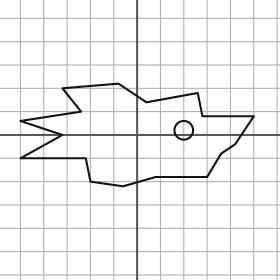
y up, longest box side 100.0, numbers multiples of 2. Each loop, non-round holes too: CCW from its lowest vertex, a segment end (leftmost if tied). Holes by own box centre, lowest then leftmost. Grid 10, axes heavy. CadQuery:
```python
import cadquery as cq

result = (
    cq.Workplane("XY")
    .moveTo(-6.0, -22.0)
    .lineTo(8.0, -18.0)
    .lineTo(30.0, -18.0)
    .lineTo(36.0, -8.0)
    .lineTo(42.0, -4.0)
    .lineTo(50.0, 8.0)
    .lineTo(28.0, 8.0)
    .lineTo(26.0, 18.0)
    .lineTo(4.0, 14.0)
    .lineTo(-8.0, 22.0)
    .lineTo(-32.0, 20.0)
    .lineTo(-24.0, 10.0)
    .lineTo(-50.0, 6.0)
    .lineTo(-32.0, 0.0)
    .lineTo(-50.0, -10.0)
    .lineTo(-22.0, -10.0)
    .lineTo(-20.0, -20.0)
    .close()
    .moveTo(20.0, 2.0)
    .circle(4.0)
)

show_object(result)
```